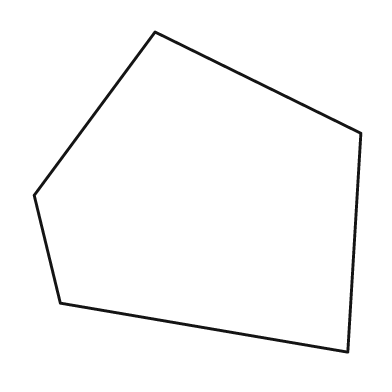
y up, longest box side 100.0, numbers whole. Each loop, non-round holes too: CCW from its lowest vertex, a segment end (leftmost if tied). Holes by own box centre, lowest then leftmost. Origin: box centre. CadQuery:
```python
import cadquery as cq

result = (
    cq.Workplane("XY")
    .moveTo(46.0, -49.0)
    .lineTo(50.0, 18.0)
    .lineTo(-13.0, 49.0)
    .lineTo(-50.0, -1.0)
    .lineTo(-42.0, -34.0)
    .close()
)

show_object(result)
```